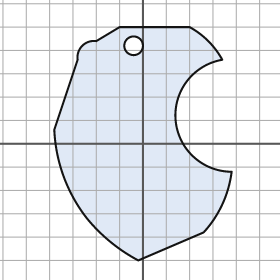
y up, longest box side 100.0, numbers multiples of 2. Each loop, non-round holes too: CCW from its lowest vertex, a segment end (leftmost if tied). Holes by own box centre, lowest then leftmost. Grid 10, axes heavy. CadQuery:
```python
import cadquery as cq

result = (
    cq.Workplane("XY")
    .moveTo(-2.0, -50.0)
    .lineTo(26.0, -38.0)
    .threePointArc((34.0, -26.0), (38.0, -12.0))
    .threePointArc((14.0, 10.0), (34.0, 36.0))
    .threePointArc((28.0, 44.0), (20.0, 50.0))
    .lineTo(-10.0, 50.0)
    .lineTo(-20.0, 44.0)
    .threePointArc((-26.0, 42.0), (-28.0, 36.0))
    .lineTo(-38.0, 6.0)
    .threePointArc((-34.0, -14.0), (-24.0, -32.0))
    .threePointArc((-14.0, -42.0), (-2.0, -50.0))
    .close()
    .moveTo(-4.0, 42.0)
    .circle(4.0)
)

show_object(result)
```